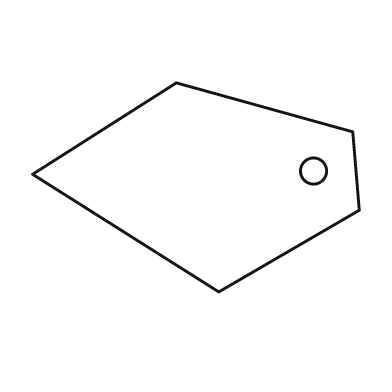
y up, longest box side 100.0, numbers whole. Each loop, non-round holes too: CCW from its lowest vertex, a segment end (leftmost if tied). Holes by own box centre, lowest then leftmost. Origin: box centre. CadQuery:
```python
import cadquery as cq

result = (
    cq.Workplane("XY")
    .moveTo(7.0, -32.0)
    .lineTo(50.0, -7.0)
    .lineTo(48.0, 17.0)
    .lineTo(-6.0, 32.0)
    .lineTo(-50.0, 4.0)
    .close()
    .moveTo(36.0, 5.0)
    .circle(4.0)
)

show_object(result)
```